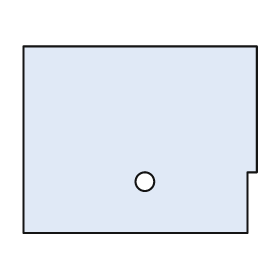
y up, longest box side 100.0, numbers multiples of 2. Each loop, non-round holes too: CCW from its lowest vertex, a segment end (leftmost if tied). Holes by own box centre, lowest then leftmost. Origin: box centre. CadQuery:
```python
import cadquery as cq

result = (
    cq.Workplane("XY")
    .moveTo(-50.0, -40.0)
    .lineTo(46.0, -40.0)
    .lineTo(46.0, -14.0)
    .lineTo(50.0, -14.0)
    .lineTo(50.0, 40.0)
    .lineTo(-50.0, 40.0)
    .close()
    .moveTo(2.0, -18.0)
    .circle(4.0)
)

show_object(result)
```